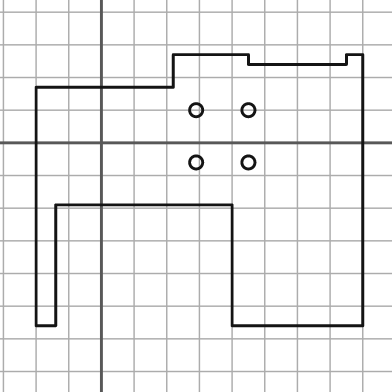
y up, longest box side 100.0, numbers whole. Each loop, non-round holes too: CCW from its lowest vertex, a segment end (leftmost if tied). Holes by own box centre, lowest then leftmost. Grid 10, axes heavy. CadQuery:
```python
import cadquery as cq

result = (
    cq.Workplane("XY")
    .moveTo(-20.0, -56.0)
    .lineTo(-14.0, -56.0)
    .lineTo(-14.0, -19.0)
    .lineTo(40.0, -19.0)
    .lineTo(40.0, -56.0)
    .lineTo(80.0, -56.0)
    .lineTo(80.0, 27.0)
    .lineTo(75.0, 27.0)
    .lineTo(75.0, 24.0)
    .lineTo(45.0, 24.0)
    .lineTo(45.0, 27.0)
    .lineTo(22.0, 27.0)
    .lineTo(22.0, 17.0)
    .lineTo(-20.0, 17.0)
    .close()
    .moveTo(29.0, -6.0)
    .circle(2.0)
    .moveTo(45.0, -6.0)
    .circle(2.0)
    .moveTo(29.0, 10.0)
    .circle(2.0)
    .moveTo(45.0, 10.0)
    .circle(2.0)
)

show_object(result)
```